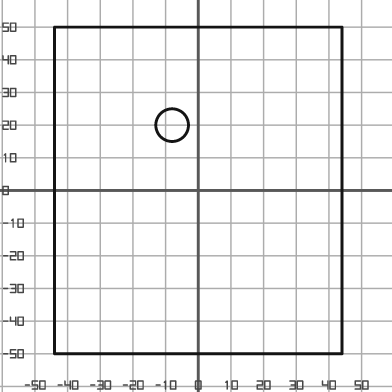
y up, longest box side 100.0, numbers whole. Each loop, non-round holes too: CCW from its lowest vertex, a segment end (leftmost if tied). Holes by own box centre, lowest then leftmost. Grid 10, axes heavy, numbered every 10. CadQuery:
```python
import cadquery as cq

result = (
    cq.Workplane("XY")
    .moveTo(-44.0, -50.0)
    .lineTo(44.0, -50.0)
    .lineTo(44.0, 50.0)
    .lineTo(-44.0, 50.0)
    .close()
    .moveTo(-8.0, 20.0)
    .circle(5.0)
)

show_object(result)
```